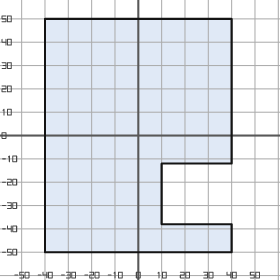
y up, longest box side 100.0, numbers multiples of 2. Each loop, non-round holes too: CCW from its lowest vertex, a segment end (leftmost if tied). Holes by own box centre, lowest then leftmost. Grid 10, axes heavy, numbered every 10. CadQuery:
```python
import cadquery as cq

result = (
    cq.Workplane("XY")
    .moveTo(-40.0, -50.0)
    .lineTo(40.0, -50.0)
    .lineTo(40.0, -38.0)
    .lineTo(10.0, -38.0)
    .lineTo(10.0, -12.0)
    .lineTo(40.0, -12.0)
    .lineTo(40.0, 50.0)
    .lineTo(-40.0, 50.0)
    .close()
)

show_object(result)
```